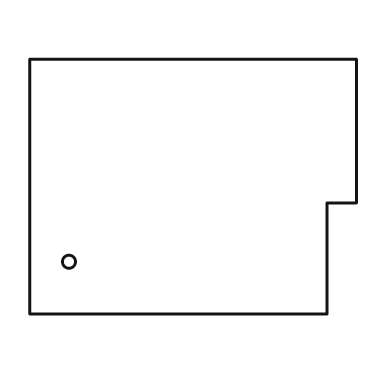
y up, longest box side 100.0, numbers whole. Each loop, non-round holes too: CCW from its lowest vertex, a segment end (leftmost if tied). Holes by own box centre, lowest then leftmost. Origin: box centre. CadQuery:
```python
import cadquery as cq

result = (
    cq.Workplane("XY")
    .moveTo(-50.0, -39.0)
    .lineTo(41.0, -39.0)
    .lineTo(41.0, -5.0)
    .lineTo(50.0, -5.0)
    .lineTo(50.0, 39.0)
    .lineTo(-50.0, 39.0)
    .close()
    .moveTo(-38.0, -23.0)
    .circle(2.0)
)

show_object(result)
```